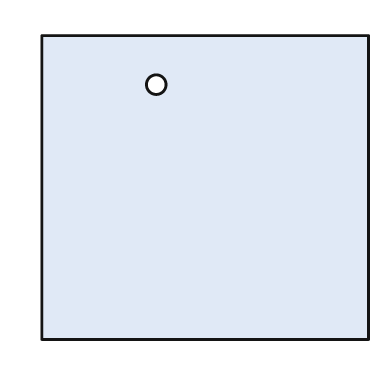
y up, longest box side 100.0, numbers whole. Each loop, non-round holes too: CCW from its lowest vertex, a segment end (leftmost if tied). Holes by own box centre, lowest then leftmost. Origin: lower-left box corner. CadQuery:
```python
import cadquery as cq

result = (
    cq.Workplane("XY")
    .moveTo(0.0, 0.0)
    .lineTo(100.0, 0.0)
    .lineTo(100.0, 93.0)
    .lineTo(0.0, 93.0)
    .close()
    .moveTo(35.0, 78.0)
    .circle(3.0)
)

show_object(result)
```